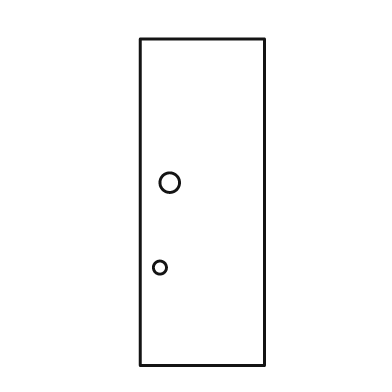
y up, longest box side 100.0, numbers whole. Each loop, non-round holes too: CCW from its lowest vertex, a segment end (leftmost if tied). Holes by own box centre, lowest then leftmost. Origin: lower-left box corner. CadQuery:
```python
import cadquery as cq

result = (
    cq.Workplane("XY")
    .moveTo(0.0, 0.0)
    .lineTo(38.0, 0.0)
    .lineTo(38.0, 100.0)
    .lineTo(0.0, 100.0)
    .close()
    .moveTo(6.0, 30.0)
    .circle(2.0)
    .moveTo(9.0, 56.0)
    .circle(3.0)
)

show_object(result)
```